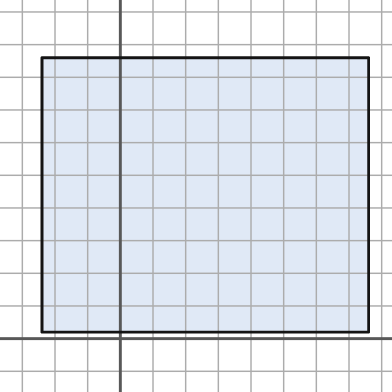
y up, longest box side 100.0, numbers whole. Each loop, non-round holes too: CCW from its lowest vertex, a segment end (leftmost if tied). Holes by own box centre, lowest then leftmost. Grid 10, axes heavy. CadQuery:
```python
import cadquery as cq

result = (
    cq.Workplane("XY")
    .moveTo(-24.0, 2.0)
    .lineTo(76.0, 2.0)
    .lineTo(76.0, 86.0)
    .lineTo(-24.0, 86.0)
    .close()
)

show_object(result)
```